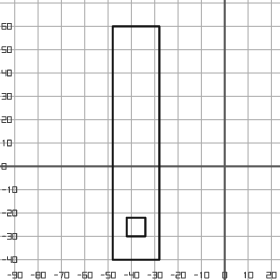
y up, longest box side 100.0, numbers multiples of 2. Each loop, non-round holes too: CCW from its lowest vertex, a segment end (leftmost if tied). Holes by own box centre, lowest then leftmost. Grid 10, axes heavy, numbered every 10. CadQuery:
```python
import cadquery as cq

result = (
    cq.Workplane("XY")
    .moveTo(-48.0, -40.0)
    .lineTo(-28.0, -40.0)
    .lineTo(-28.0, 60.0)
    .lineTo(-48.0, 60.0)
    .close()
    .moveTo(-42.0, -30.0)
    .lineTo(-34.0, -30.0)
    .lineTo(-34.0, -22.0)
    .lineTo(-42.0, -22.0)
    .close()
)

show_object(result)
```